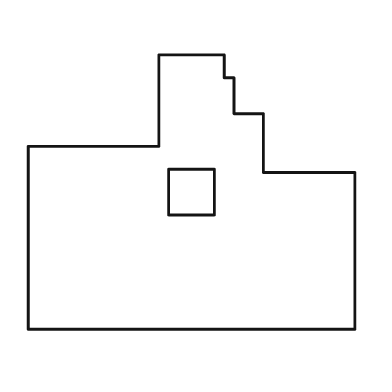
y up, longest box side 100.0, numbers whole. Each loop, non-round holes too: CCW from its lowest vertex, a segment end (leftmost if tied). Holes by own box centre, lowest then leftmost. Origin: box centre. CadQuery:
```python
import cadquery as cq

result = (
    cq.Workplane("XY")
    .moveTo(-50.0, -42.0)
    .lineTo(50.0, -42.0)
    .lineTo(50.0, 6.0)
    .lineTo(22.0, 6.0)
    .lineTo(22.0, 24.0)
    .lineTo(13.0, 24.0)
    .lineTo(13.0, 35.0)
    .lineTo(10.0, 35.0)
    .lineTo(10.0, 42.0)
    .lineTo(-10.0, 42.0)
    .lineTo(-10.0, 14.0)
    .lineTo(-50.0, 14.0)
    .close()
    .moveTo(-7.0, -7.0)
    .lineTo(7.0, -7.0)
    .lineTo(7.0, 7.0)
    .lineTo(-7.0, 7.0)
    .close()
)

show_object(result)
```